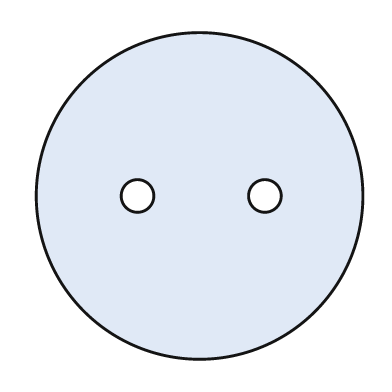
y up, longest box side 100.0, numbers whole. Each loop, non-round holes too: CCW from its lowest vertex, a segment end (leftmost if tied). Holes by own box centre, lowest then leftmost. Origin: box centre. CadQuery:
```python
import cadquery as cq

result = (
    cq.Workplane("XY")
    .moveTo(0.0, 0.0)
    .circle(50.0)
    .moveTo(-19.0, 0.0)
    .circle(5.0)
    .moveTo(20.0, 0.0)
    .circle(5.0)
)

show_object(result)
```